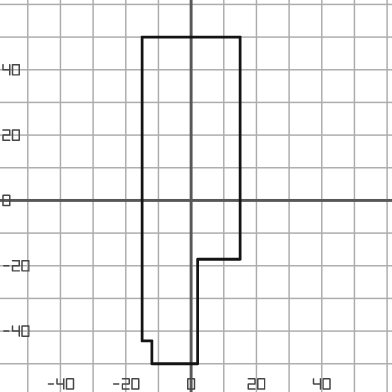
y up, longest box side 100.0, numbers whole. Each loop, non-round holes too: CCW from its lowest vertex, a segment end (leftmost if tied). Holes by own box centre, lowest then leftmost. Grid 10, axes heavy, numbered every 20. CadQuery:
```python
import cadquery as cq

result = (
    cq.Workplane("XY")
    .moveTo(-12.0, -50.0)
    .lineTo(2.0, -50.0)
    .lineTo(2.0, -18.0)
    .lineTo(15.0, -18.0)
    .lineTo(15.0, 50.0)
    .lineTo(-15.0, 50.0)
    .lineTo(-15.0, -43.0)
    .lineTo(-12.0, -43.0)
    .close()
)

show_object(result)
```